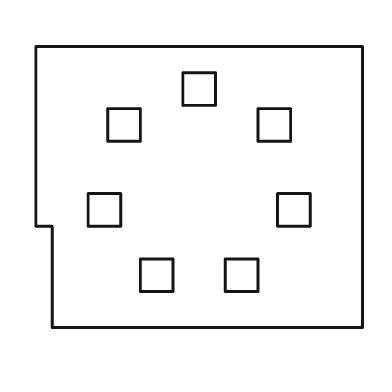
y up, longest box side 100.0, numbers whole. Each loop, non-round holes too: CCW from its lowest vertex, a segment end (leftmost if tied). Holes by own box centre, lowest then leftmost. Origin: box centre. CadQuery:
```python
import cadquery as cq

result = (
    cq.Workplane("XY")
    .moveTo(-45.0, -43.0)
    .lineTo(50.0, -43.0)
    .lineTo(50.0, 43.0)
    .lineTo(-50.0, 43.0)
    .lineTo(-50.0, -12.0)
    .lineTo(-45.0, -12.0)
    .close()
    .moveTo(-18.0, -32.0)
    .lineTo(-8.0, -32.0)
    .lineTo(-8.0, -22.0)
    .lineTo(-18.0, -22.0)
    .close()
    .moveTo(8.0, -32.0)
    .lineTo(18.0, -32.0)
    .lineTo(18.0, -22.0)
    .lineTo(8.0, -22.0)
    .close()
    .moveTo(-34.0, -12.0)
    .lineTo(-24.0, -12.0)
    .lineTo(-24.0, -2.0)
    .lineTo(-34.0, -2.0)
    .close()
    .moveTo(24.0, -12.0)
    .lineTo(34.0, -12.0)
    .lineTo(34.0, -2.0)
    .lineTo(24.0, -2.0)
    .close()
    .moveTo(-28.0, 14.0)
    .lineTo(-18.0, 14.0)
    .lineTo(-18.0, 24.0)
    .lineTo(-28.0, 24.0)
    .close()
    .moveTo(18.0, 14.0)
    .lineTo(28.0, 14.0)
    .lineTo(28.0, 24.0)
    .lineTo(18.0, 24.0)
    .close()
    .moveTo(-5.0, 25.0)
    .lineTo(5.0, 25.0)
    .lineTo(5.0, 35.0)
    .lineTo(-5.0, 35.0)
    .close()
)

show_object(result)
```